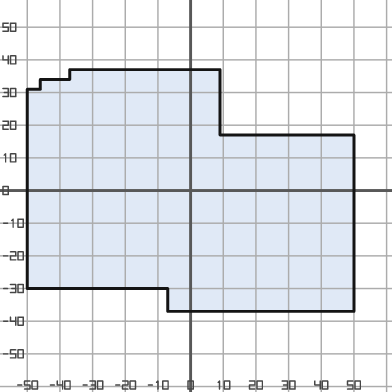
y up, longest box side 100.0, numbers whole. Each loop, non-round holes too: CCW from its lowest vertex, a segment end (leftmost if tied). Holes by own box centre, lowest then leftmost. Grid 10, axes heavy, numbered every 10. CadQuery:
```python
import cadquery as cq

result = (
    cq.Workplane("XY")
    .moveTo(-7.0, -37.0)
    .lineTo(50.0, -37.0)
    .lineTo(50.0, 17.0)
    .lineTo(9.0, 17.0)
    .lineTo(9.0, 37.0)
    .lineTo(-37.0, 37.0)
    .lineTo(-37.0, 34.0)
    .lineTo(-46.0, 34.0)
    .lineTo(-46.0, 31.0)
    .lineTo(-50.0, 31.0)
    .lineTo(-50.0, -30.0)
    .lineTo(-7.0, -30.0)
    .close()
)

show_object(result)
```